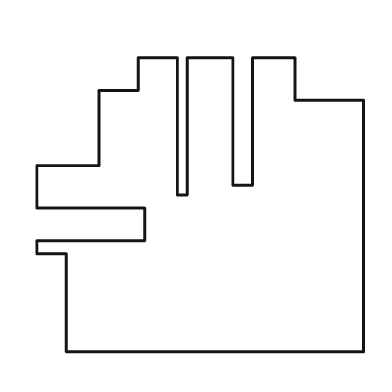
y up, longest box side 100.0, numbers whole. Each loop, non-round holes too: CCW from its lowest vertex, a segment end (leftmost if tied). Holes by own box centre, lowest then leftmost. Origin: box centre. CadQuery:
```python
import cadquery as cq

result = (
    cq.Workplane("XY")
    .moveTo(-41.0, -45.0)
    .lineTo(50.0, -45.0)
    .lineTo(50.0, 32.0)
    .lineTo(29.0, 32.0)
    .lineTo(29.0, 45.0)
    .lineTo(16.0, 45.0)
    .lineTo(16.0, 6.0)
    .lineTo(10.0, 6.0)
    .lineTo(10.0, 45.0)
    .lineTo(-4.0, 45.0)
    .lineTo(-4.0, 3.0)
    .lineTo(-7.0, 3.0)
    .lineTo(-7.0, 45.0)
    .lineTo(-19.0, 45.0)
    .lineTo(-19.0, 35.0)
    .lineTo(-31.0, 35.0)
    .lineTo(-31.0, 12.0)
    .lineTo(-50.0, 12.0)
    .lineTo(-50.0, -1.0)
    .lineTo(-17.0, -1.0)
    .lineTo(-17.0, -11.0)
    .lineTo(-50.0, -11.0)
    .lineTo(-50.0, -15.0)
    .lineTo(-41.0, -15.0)
    .close()
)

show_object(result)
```